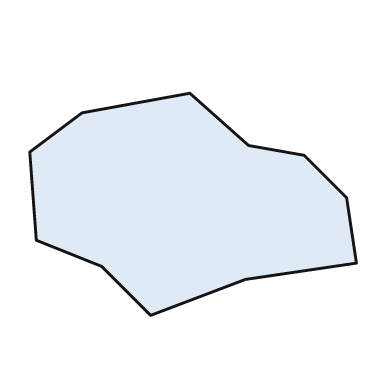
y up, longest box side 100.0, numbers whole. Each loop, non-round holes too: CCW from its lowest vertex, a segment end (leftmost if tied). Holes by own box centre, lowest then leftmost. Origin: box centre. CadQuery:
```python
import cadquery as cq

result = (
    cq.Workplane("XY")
    .moveTo(-13.0, -34.0)
    .lineTo(16.0, -23.0)
    .lineTo(50.0, -18.0)
    .lineTo(47.0, 2.0)
    .lineTo(34.0, 15.0)
    .lineTo(17.0, 18.0)
    .lineTo(-1.0, 34.0)
    .lineTo(-34.0, 28.0)
    .lineTo(-50.0, 16.0)
    .lineTo(-48.0, -11.0)
    .lineTo(-28.0, -19.0)
    .close()
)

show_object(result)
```